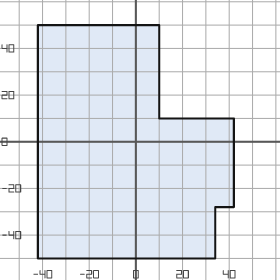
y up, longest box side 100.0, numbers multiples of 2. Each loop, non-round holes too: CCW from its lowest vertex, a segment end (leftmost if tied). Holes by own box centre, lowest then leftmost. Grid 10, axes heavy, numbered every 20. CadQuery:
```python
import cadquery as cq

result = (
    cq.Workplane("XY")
    .moveTo(-42.0, -50.0)
    .lineTo(34.0, -50.0)
    .lineTo(34.0, -28.0)
    .lineTo(42.0, -28.0)
    .lineTo(42.0, 10.0)
    .lineTo(10.0, 10.0)
    .lineTo(10.0, 50.0)
    .lineTo(-42.0, 50.0)
    .close()
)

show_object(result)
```